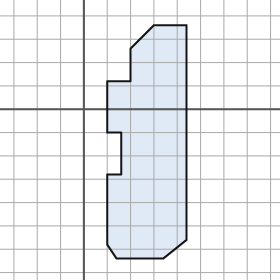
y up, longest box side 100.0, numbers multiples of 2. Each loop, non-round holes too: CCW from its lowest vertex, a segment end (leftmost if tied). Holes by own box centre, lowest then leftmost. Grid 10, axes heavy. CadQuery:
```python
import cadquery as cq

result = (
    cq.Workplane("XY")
    .moveTo(14.0, -64.0)
    .lineTo(34.0, -64.0)
    .lineTo(44.0, -56.0)
    .lineTo(44.0, 36.0)
    .lineTo(30.0, 36.0)
    .lineTo(20.0, 26.0)
    .lineTo(20.0, 12.0)
    .lineTo(10.0, 12.0)
    .lineTo(10.0, -10.0)
    .lineTo(16.0, -10.0)
    .lineTo(16.0, -28.0)
    .lineTo(10.0, -28.0)
    .lineTo(10.0, -58.0)
    .close()
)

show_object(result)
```